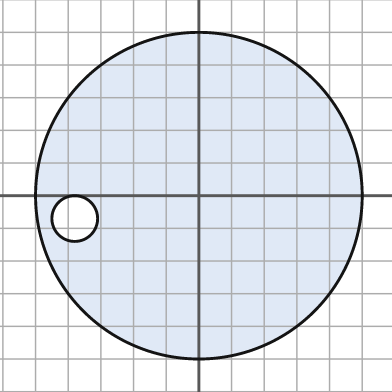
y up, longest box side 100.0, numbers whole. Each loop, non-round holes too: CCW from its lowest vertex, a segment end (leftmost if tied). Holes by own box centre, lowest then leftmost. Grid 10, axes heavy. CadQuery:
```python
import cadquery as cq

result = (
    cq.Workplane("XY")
    .moveTo(0.0, 0.0)
    .circle(50.0)
    .moveTo(-38.0, -7.0)
    .circle(7.0)
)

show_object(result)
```